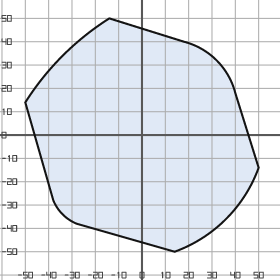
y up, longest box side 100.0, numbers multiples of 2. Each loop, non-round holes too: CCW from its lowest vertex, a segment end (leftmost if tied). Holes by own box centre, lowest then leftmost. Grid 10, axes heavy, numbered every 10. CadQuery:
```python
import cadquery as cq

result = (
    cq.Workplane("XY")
    .moveTo(14.0, -50.0)
    .threePointArc((36.0, -36.0), (50.0, -14.0))
    .lineTo(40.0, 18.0)
    .threePointArc((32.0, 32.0), (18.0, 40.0))
    .lineTo(-14.0, 50.0)
    .threePointArc((-34.0, 34.0), (-50.0, 14.0))
    .lineTo(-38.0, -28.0)
    .threePointArc((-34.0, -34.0), (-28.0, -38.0))
    .close()
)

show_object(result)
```